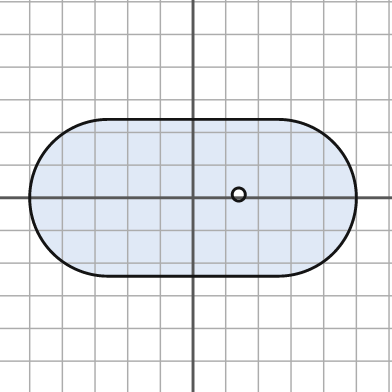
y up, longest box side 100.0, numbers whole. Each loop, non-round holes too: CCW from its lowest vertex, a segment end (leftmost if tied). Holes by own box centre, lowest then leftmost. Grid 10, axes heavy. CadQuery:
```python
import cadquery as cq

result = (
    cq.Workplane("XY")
    .moveTo(-26.0, -24.0)
    .lineTo(26.0, -24.0)
    .threePointArc((50.0, 0.0), (26.0, 24.0))
    .lineTo(-26.0, 24.0)
    .threePointArc((-50.0, 0.0), (-26.0, -24.0))
    .close()
    .moveTo(14.0, 1.0)
    .circle(2.0)
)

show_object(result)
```